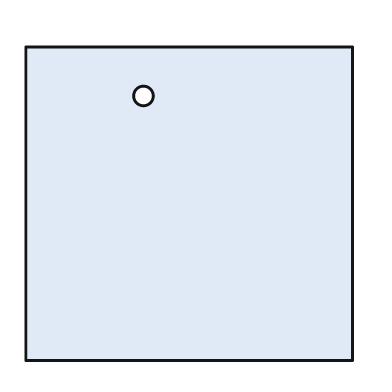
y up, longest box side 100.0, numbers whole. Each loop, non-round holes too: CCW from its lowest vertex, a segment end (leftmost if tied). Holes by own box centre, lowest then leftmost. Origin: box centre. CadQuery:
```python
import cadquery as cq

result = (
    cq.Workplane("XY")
    .moveTo(-50.0, -48.0)
    .lineTo(50.0, -48.0)
    .lineTo(50.0, 48.0)
    .lineTo(-50.0, 48.0)
    .close()
    .moveTo(-14.0, 33.0)
    .circle(3.0)
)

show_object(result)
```